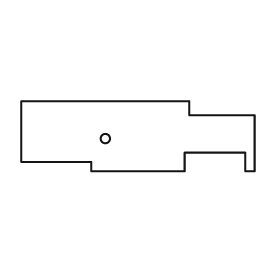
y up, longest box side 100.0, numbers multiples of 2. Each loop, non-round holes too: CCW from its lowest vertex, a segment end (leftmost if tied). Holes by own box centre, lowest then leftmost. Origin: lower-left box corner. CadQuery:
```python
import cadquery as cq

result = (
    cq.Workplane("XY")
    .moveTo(30.0, 0.0)
    .lineTo(70.0, 0.0)
    .lineTo(70.0, 8.0)
    .lineTo(96.0, 8.0)
    .lineTo(96.0, 0.0)
    .lineTo(100.0, 0.0)
    .lineTo(100.0, 24.0)
    .lineTo(72.0, 24.0)
    .lineTo(72.0, 30.0)
    .lineTo(0.0, 30.0)
    .lineTo(0.0, 4.0)
    .lineTo(30.0, 4.0)
    .close()
    .moveTo(36.0, 14.0)
    .circle(2.0)
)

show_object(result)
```